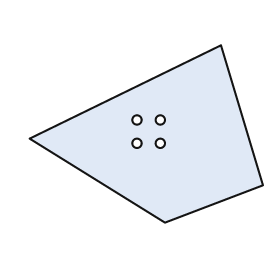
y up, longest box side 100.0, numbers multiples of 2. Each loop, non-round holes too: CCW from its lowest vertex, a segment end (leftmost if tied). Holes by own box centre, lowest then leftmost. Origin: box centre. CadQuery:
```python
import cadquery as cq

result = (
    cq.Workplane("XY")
    .moveTo(8.0, -38.0)
    .lineTo(50.0, -22.0)
    .lineTo(32.0, 38.0)
    .lineTo(-50.0, -2.0)
    .close()
    .moveTo(-4.0, -4.0)
    .circle(2.0)
    .moveTo(6.0, -4.0)
    .circle(2.0)
    .moveTo(-4.0, 6.0)
    .circle(2.0)
    .moveTo(6.0, 6.0)
    .circle(2.0)
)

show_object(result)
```